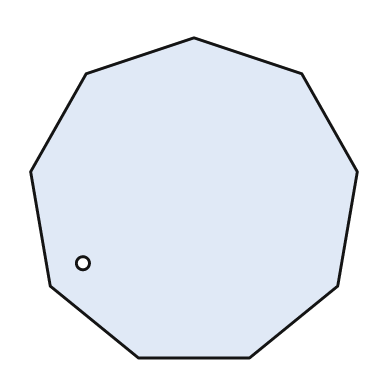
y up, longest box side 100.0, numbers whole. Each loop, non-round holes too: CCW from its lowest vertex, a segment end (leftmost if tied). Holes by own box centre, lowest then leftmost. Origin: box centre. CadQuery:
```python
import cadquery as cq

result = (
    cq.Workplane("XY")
    .moveTo(-17.0, -49.0)
    .lineTo(17.0, -49.0)
    .lineTo(44.0, -27.0)
    .lineTo(50.0, 8.0)
    .lineTo(33.0, 38.0)
    .lineTo(0.0, 49.0)
    .lineTo(-33.0, 38.0)
    .lineTo(-50.0, 8.0)
    .lineTo(-44.0, -27.0)
    .close()
    .moveTo(-34.0, -20.0)
    .circle(2.0)
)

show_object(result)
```